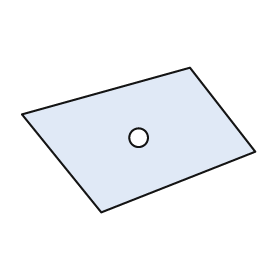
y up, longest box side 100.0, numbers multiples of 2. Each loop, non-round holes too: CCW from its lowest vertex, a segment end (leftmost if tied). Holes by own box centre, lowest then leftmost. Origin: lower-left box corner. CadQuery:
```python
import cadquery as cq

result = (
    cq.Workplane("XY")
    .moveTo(34.0, 0.0)
    .lineTo(100.0, 26.0)
    .lineTo(72.0, 62.0)
    .lineTo(0.0, 42.0)
    .close()
    .moveTo(50.0, 32.0)
    .circle(4.0)
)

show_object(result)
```